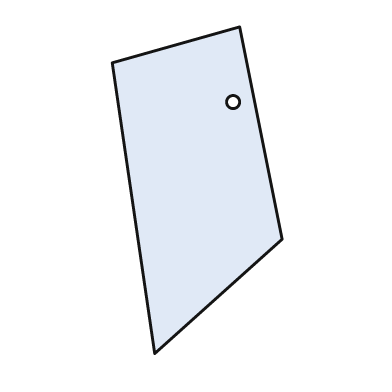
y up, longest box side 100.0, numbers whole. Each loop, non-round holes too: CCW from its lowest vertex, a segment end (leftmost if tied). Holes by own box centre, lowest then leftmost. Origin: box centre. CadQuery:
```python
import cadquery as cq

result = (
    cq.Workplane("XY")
    .moveTo(-13.0, -50.0)
    .lineTo(26.0, -15.0)
    .lineTo(13.0, 50.0)
    .lineTo(-26.0, 39.0)
    .close()
    .moveTo(11.0, 27.0)
    .circle(2.0)
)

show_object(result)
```